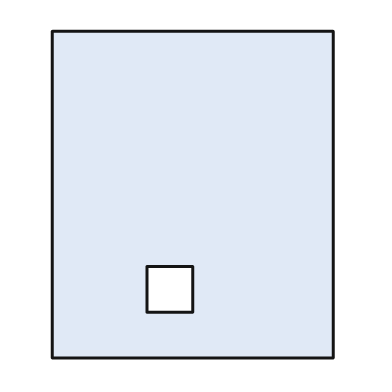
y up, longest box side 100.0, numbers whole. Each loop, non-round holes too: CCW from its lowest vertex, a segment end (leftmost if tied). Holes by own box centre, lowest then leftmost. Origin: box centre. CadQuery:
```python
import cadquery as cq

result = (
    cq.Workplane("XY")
    .moveTo(-43.0, -50.0)
    .lineTo(43.0, -50.0)
    .lineTo(43.0, 50.0)
    .lineTo(-43.0, 50.0)
    .close()
    .moveTo(-14.0, -36.0)
    .lineTo(0.0, -36.0)
    .lineTo(0.0, -22.0)
    .lineTo(-14.0, -22.0)
    .close()
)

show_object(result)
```